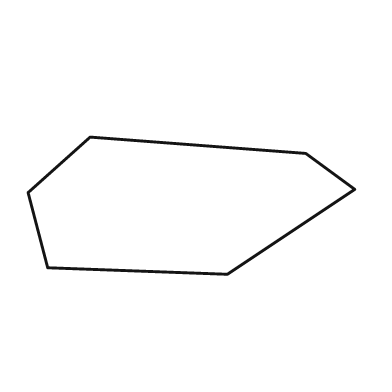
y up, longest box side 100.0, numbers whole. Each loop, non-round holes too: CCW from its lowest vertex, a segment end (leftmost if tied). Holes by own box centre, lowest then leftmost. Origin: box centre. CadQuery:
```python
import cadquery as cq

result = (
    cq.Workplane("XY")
    .moveTo(11.0, -21.0)
    .lineTo(50.0, 5.0)
    .lineTo(35.0, 16.0)
    .lineTo(-31.0, 21.0)
    .lineTo(-50.0, 4.0)
    .lineTo(-44.0, -19.0)
    .close()
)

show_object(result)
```